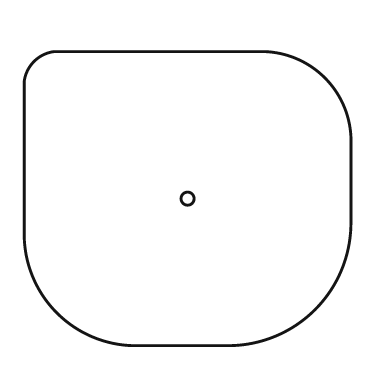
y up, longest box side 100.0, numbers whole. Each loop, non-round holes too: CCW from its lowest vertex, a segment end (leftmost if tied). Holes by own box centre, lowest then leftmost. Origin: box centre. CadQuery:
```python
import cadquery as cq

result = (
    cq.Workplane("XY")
    .moveTo(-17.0, -45.0)
    .lineTo(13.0, -45.0)
    .threePointArc((39.0, -34.0), (50.0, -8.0))
    .lineTo(50.0, 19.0)
    .threePointArc((42.0, 37.0), (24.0, 45.0))
    .lineTo(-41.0, 45.0)
    .threePointArc((-47.0, 42.0), (-50.0, 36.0))
    .lineTo(-50.0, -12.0)
    .threePointArc((-40.0, -35.0), (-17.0, -45.0))
    .close()
    .moveTo(0.0, 0.0)
    .circle(2.0)
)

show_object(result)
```